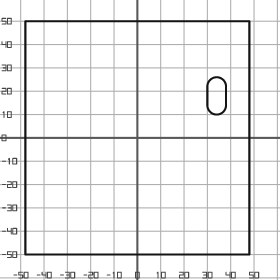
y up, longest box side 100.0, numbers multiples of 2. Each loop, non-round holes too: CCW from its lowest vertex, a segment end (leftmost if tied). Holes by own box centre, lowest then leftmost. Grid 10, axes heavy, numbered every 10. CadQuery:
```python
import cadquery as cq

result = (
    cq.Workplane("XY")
    .moveTo(-48.0, -50.0)
    .lineTo(48.0, -50.0)
    .lineTo(48.0, 50.0)
    .lineTo(-48.0, 50.0)
    .close()
    .moveTo(30.0, 14.0)
    .threePointArc((34.0, 10.0), (38.0, 14.0))
    .lineTo(38.0, 22.0)
    .threePointArc((34.0, 26.0), (30.0, 22.0))
    .close()
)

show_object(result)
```